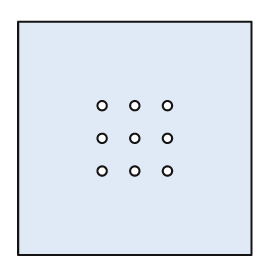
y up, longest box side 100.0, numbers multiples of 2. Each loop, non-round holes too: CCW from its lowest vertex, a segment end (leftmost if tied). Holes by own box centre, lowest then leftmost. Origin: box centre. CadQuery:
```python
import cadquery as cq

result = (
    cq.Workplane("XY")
    .moveTo(-50.0, -50.0)
    .lineTo(50.0, -50.0)
    .lineTo(50.0, 50.0)
    .lineTo(-50.0, 50.0)
    .close()
    .moveTo(-14.0, -14.0)
    .circle(2.0)
    .moveTo(0.0, -14.0)
    .circle(2.0)
    .moveTo(14.0, -14.0)
    .circle(2.0)
    .moveTo(-14.0, 0.0)
    .circle(2.0)
    .moveTo(0.0, 0.0)
    .circle(2.0)
    .moveTo(14.0, 0.0)
    .circle(2.0)
    .moveTo(-14.0, 14.0)
    .circle(2.0)
    .moveTo(0.0, 14.0)
    .circle(2.0)
    .moveTo(14.0, 14.0)
    .circle(2.0)
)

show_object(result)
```